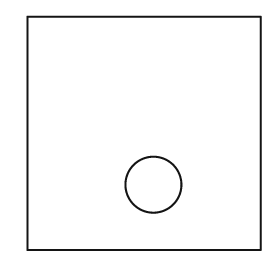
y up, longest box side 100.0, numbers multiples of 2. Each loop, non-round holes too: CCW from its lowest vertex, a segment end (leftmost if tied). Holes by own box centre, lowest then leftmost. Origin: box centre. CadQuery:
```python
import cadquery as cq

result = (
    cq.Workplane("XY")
    .moveTo(-50.0, -50.0)
    .lineTo(50.0, -50.0)
    .lineTo(50.0, 50.0)
    .lineTo(-50.0, 50.0)
    .close()
    .moveTo(4.0, -22.0)
    .circle(12.0)
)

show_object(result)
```